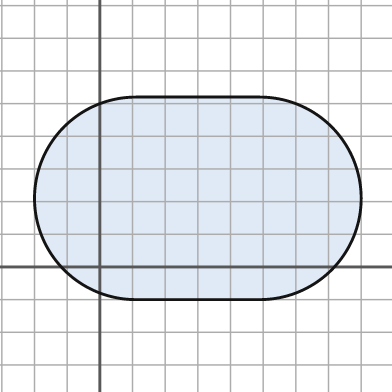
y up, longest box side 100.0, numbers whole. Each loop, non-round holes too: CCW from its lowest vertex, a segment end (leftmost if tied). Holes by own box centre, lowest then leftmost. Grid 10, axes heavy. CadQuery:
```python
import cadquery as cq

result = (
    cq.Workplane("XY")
    .moveTo(11.0, -10.0)
    .lineTo(49.0, -10.0)
    .threePointArc((80.0, 21.0), (49.0, 52.0))
    .lineTo(11.0, 52.0)
    .threePointArc((-20.0, 21.0), (11.0, -10.0))
    .close()
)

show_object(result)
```